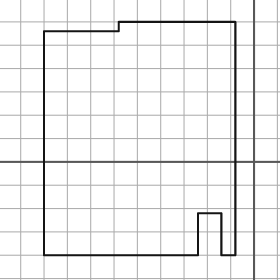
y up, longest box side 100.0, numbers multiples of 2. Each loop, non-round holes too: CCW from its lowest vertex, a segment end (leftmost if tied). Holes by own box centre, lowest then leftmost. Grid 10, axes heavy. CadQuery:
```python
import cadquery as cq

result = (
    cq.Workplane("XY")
    .moveTo(-90.0, -40.0)
    .lineTo(-24.0, -40.0)
    .lineTo(-24.0, -22.0)
    .lineTo(-14.0, -22.0)
    .lineTo(-14.0, -40.0)
    .lineTo(-8.0, -40.0)
    .lineTo(-8.0, 60.0)
    .lineTo(-58.0, 60.0)
    .lineTo(-58.0, 56.0)
    .lineTo(-90.0, 56.0)
    .close()
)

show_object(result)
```